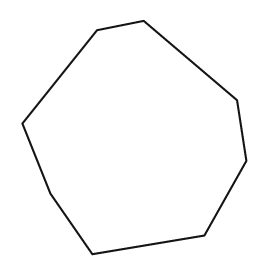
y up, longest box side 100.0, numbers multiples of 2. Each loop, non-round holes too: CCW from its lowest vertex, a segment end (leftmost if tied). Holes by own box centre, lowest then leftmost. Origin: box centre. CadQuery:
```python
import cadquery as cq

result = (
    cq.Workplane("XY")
    .moveTo(-18.0, -50.0)
    .lineTo(30.0, -42.0)
    .lineTo(48.0, -10.0)
    .lineTo(44.0, 16.0)
    .lineTo(4.0, 50.0)
    .lineTo(-16.0, 46.0)
    .lineTo(-48.0, 6.0)
    .lineTo(-36.0, -24.0)
    .close()
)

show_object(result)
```